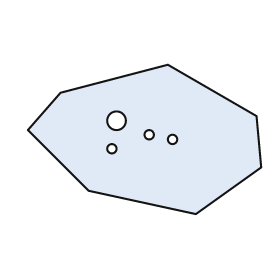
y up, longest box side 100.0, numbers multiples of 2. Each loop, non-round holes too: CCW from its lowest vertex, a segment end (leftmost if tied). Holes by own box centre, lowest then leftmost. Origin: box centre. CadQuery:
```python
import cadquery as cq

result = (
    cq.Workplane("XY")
    .moveTo(22.0, -32.0)
    .lineTo(50.0, -12.0)
    .lineTo(48.0, 10.0)
    .lineTo(10.0, 32.0)
    .lineTo(-36.0, 20.0)
    .lineTo(-50.0, 4.0)
    .lineTo(-24.0, -22.0)
    .close()
    .moveTo(-14.0, -4.0)
    .circle(2.0)
    .moveTo(12.0, 0.0)
    .circle(2.0)
    .moveTo(2.0, 2.0)
    .circle(2.0)
    .moveTo(-12.0, 8.0)
    .circle(4.0)
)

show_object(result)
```